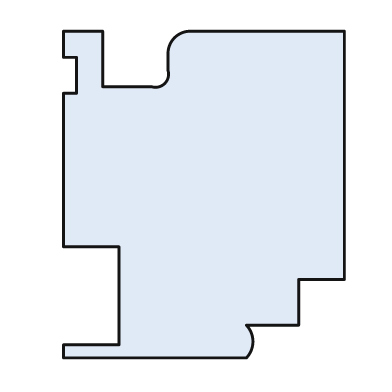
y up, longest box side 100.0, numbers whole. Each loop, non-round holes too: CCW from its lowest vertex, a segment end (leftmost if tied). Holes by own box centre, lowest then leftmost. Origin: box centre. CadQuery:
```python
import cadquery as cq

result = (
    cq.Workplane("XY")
    .moveTo(-43.0, -50.0)
    .lineTo(13.0, -50.0)
    .threePointArc((15.0, -45.0), (13.0, -40.0))
    .lineTo(29.0, -40.0)
    .lineTo(29.0, -26.0)
    .lineTo(43.0, -26.0)
    .lineTo(43.0, 50.0)
    .lineTo(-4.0, 50.0)
    .threePointArc((-9.0, 48.0), (-11.0, 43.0))
    .lineTo(-11.0, 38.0)
    .threePointArc((-12.0, 34.0), (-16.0, 33.0))
    .lineTo(-31.0, 33.0)
    .lineTo(-31.0, 50.0)
    .lineTo(-43.0, 50.0)
    .lineTo(-43.0, 42.0)
    .lineTo(-39.0, 42.0)
    .lineTo(-39.0, 31.0)
    .lineTo(-43.0, 31.0)
    .lineTo(-43.0, -16.0)
    .lineTo(-26.0, -16.0)
    .lineTo(-26.0, -46.0)
    .lineTo(-43.0, -46.0)
    .close()
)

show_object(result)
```